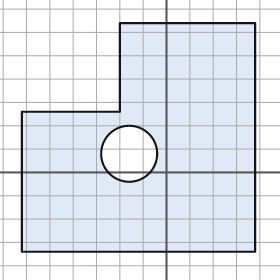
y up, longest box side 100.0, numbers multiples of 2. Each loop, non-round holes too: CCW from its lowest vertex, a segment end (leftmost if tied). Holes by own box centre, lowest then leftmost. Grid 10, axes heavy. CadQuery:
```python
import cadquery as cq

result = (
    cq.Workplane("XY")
    .moveTo(-62.0, -34.0)
    .lineTo(38.0, -34.0)
    .lineTo(38.0, 64.0)
    .lineTo(-20.0, 64.0)
    .lineTo(-20.0, 26.0)
    .lineTo(-62.0, 26.0)
    .close()
    .moveTo(-16.0, 8.0)
    .circle(12.0)
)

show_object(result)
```